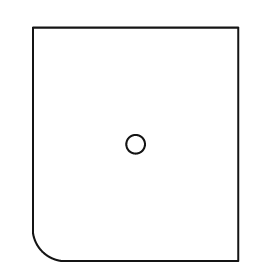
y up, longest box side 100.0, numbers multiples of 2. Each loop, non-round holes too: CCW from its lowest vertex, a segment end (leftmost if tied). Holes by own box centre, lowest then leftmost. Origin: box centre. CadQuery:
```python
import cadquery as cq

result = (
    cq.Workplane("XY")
    .moveTo(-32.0, -50.0)
    .lineTo(44.0, -50.0)
    .lineTo(44.0, 50.0)
    .lineTo(-44.0, 50.0)
    .lineTo(-44.0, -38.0)
    .threePointArc((-40.0, -46.0), (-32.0, -50.0))
    .close()
    .moveTo(0.0, 0.0)
    .circle(4.0)
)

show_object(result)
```